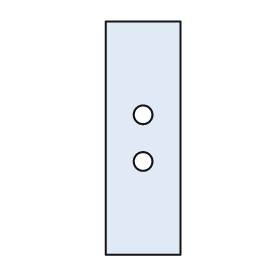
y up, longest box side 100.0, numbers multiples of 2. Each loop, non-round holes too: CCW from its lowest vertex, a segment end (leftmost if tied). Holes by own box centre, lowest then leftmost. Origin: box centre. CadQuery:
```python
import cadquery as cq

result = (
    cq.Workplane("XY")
    .moveTo(-16.0, -50.0)
    .lineTo(16.0, -50.0)
    .lineTo(16.0, 50.0)
    .lineTo(-16.0, 50.0)
    .close()
    .moveTo(0.0, -10.0)
    .circle(4.0)
    .moveTo(0.0, 10.0)
    .circle(4.0)
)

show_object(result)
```